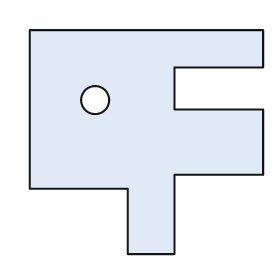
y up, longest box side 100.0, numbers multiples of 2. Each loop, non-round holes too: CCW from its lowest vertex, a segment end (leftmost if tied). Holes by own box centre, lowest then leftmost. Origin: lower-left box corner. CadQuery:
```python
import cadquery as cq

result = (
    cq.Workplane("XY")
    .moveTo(42.0, 0.0)
    .lineTo(62.0, 0.0)
    .lineTo(62.0, 34.0)
    .lineTo(100.0, 34.0)
    .lineTo(100.0, 62.0)
    .lineTo(62.0, 62.0)
    .lineTo(62.0, 80.0)
    .lineTo(100.0, 80.0)
    .lineTo(100.0, 96.0)
    .lineTo(0.0, 96.0)
    .lineTo(0.0, 28.0)
    .lineTo(42.0, 28.0)
    .close()
    .moveTo(28.0, 66.0)
    .circle(6.0)
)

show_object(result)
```